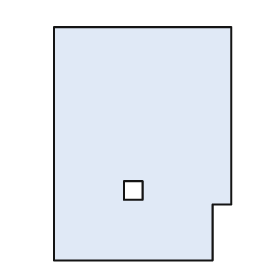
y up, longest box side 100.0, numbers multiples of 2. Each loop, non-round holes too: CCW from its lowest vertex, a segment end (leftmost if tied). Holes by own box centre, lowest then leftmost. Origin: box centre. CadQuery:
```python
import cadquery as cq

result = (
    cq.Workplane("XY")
    .moveTo(-38.0, -50.0)
    .lineTo(30.0, -50.0)
    .lineTo(30.0, -26.0)
    .lineTo(38.0, -26.0)
    .lineTo(38.0, 50.0)
    .lineTo(-38.0, 50.0)
    .close()
    .moveTo(-8.0, -24.0)
    .lineTo(0.0, -24.0)
    .lineTo(0.0, -16.0)
    .lineTo(-8.0, -16.0)
    .close()
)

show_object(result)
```